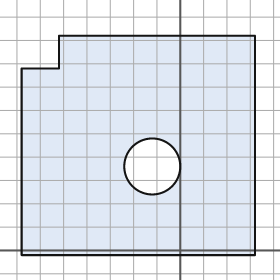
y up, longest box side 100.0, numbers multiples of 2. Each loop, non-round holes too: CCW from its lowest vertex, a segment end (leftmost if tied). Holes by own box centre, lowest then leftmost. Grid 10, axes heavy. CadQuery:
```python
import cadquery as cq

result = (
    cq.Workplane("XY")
    .moveTo(-68.0, -2.0)
    .lineTo(32.0, -2.0)
    .lineTo(32.0, 92.0)
    .lineTo(-52.0, 92.0)
    .lineTo(-52.0, 78.0)
    .lineTo(-68.0, 78.0)
    .close()
    .moveTo(-12.0, 36.0)
    .circle(12.0)
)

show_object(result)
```